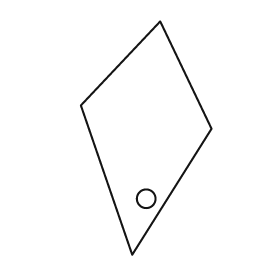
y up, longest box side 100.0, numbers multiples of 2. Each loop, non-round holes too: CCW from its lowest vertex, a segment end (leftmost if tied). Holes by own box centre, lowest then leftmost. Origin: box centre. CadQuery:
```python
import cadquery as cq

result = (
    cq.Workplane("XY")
    .moveTo(-6.0, -50.0)
    .lineTo(28.0, 4.0)
    .lineTo(6.0, 50.0)
    .lineTo(-28.0, 14.0)
    .close()
    .moveTo(0.0, -26.0)
    .circle(4.0)
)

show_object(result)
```